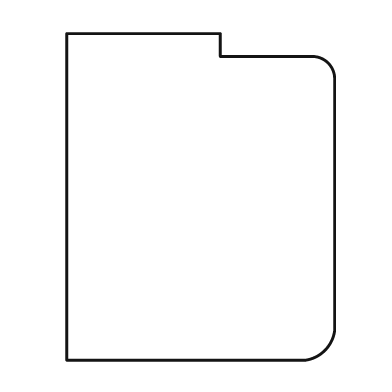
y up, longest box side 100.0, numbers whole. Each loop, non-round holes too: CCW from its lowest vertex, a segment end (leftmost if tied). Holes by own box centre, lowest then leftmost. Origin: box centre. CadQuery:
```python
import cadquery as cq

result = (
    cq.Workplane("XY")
    .moveTo(-41.0, -50.0)
    .lineTo(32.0, -50.0)
    .threePointArc((38.0, -47.0), (41.0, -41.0))
    .lineTo(41.0, 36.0)
    .threePointArc((39.0, 41.0), (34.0, 43.0))
    .lineTo(6.0, 43.0)
    .lineTo(6.0, 50.0)
    .lineTo(-41.0, 50.0)
    .close()
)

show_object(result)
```